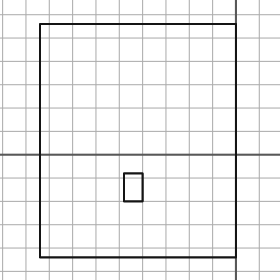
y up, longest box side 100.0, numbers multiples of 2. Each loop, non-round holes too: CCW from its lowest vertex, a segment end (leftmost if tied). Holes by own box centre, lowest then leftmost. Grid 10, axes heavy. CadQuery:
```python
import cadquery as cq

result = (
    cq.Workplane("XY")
    .moveTo(-84.0, -44.0)
    .lineTo(0.0, -44.0)
    .lineTo(0.0, 56.0)
    .lineTo(-84.0, 56.0)
    .close()
    .moveTo(-48.0, -20.0)
    .lineTo(-40.0, -20.0)
    .lineTo(-40.0, -8.0)
    .lineTo(-48.0, -8.0)
    .close()
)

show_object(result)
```